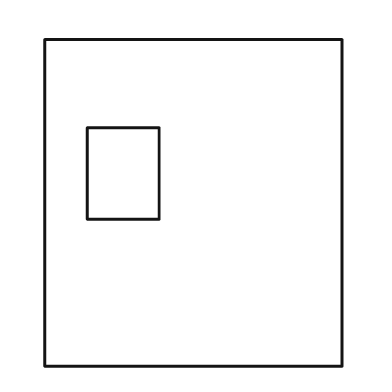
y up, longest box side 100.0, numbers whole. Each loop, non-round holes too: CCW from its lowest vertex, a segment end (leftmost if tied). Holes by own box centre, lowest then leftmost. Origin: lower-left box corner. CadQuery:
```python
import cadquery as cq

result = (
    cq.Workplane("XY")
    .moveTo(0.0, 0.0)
    .lineTo(91.0, 0.0)
    .lineTo(91.0, 100.0)
    .lineTo(0.0, 100.0)
    .close()
    .moveTo(13.0, 45.0)
    .lineTo(35.0, 45.0)
    .lineTo(35.0, 73.0)
    .lineTo(13.0, 73.0)
    .close()
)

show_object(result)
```